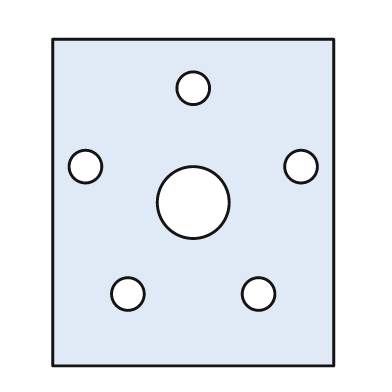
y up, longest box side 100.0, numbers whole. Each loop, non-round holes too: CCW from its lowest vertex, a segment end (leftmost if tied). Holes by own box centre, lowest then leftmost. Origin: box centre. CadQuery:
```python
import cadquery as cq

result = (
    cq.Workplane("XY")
    .moveTo(-43.0, -50.0)
    .lineTo(43.0, -50.0)
    .lineTo(43.0, 50.0)
    .lineTo(-43.0, 50.0)
    .close()
    .moveTo(-20.0, -28.0)
    .circle(5.0)
    .moveTo(20.0, -28.0)
    .circle(5.0)
    .moveTo(0.0, 0.0)
    .circle(11.0)
    .moveTo(-33.0, 11.0)
    .circle(5.0)
    .moveTo(33.0, 11.0)
    .circle(5.0)
    .moveTo(0.0, 35.0)
    .circle(5.0)
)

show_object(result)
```